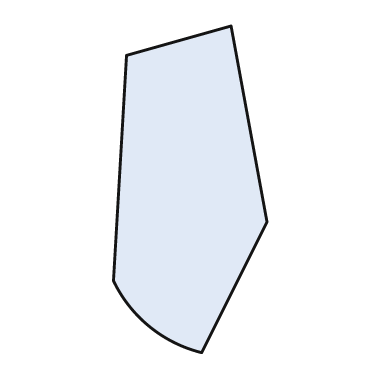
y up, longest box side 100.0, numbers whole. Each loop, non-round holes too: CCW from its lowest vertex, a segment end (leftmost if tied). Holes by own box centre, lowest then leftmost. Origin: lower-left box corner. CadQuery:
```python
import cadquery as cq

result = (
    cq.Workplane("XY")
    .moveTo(27.0, 0.0)
    .lineTo(47.0, 40.0)
    .lineTo(36.0, 100.0)
    .lineTo(4.0, 91.0)
    .lineTo(0.0, 22.0)
    .threePointArc((11.0, 8.0), (27.0, 0.0))
    .close()
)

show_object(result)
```